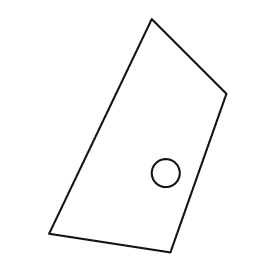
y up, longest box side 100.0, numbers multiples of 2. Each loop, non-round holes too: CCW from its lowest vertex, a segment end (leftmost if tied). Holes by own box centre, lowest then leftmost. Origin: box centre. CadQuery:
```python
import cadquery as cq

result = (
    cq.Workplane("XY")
    .moveTo(14.0, -50.0)
    .lineTo(38.0, 18.0)
    .lineTo(6.0, 50.0)
    .lineTo(-38.0, -42.0)
    .close()
    .moveTo(12.0, -16.0)
    .circle(6.0)
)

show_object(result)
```